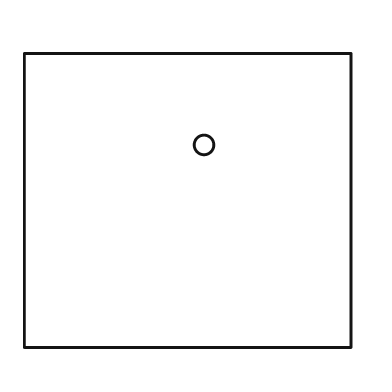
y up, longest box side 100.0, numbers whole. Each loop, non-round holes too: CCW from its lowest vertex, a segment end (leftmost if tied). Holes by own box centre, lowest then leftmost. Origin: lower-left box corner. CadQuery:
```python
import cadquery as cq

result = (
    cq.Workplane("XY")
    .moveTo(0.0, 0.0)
    .lineTo(100.0, 0.0)
    .lineTo(100.0, 90.0)
    .lineTo(0.0, 90.0)
    .close()
    .moveTo(55.0, 62.0)
    .circle(3.0)
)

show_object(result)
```